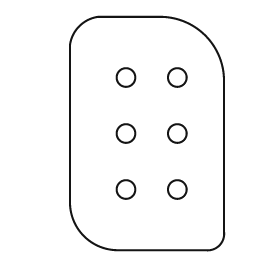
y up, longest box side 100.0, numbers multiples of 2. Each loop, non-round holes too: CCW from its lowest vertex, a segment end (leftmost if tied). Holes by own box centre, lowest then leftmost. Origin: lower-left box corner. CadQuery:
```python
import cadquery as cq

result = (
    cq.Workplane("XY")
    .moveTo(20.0, 0.0)
    .lineTo(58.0, 0.0)
    .threePointArc((64.0, 2.0), (66.0, 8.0))
    .lineTo(66.0, 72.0)
    .threePointArc((58.0, 92.0), (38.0, 100.0))
    .lineTo(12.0, 100.0)
    .threePointArc((4.0, 96.0), (0.0, 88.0))
    .lineTo(0.0, 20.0)
    .threePointArc((6.0, 6.0), (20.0, 0.0))
    .close()
    .moveTo(24.0, 26.0)
    .circle(4.0)
    .moveTo(46.0, 26.0)
    .circle(4.0)
    .moveTo(24.0, 50.0)
    .circle(4.0)
    .moveTo(46.0, 50.0)
    .circle(4.0)
    .moveTo(24.0, 74.0)
    .circle(4.0)
    .moveTo(46.0, 74.0)
    .circle(4.0)
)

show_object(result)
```